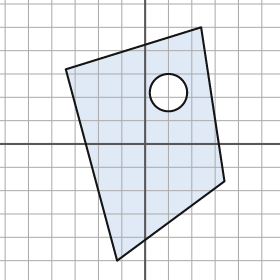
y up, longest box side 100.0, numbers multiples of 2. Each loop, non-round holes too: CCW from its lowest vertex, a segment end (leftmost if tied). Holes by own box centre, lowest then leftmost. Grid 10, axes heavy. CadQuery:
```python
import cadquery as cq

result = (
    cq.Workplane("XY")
    .moveTo(-12.0, -50.0)
    .lineTo(34.0, -16.0)
    .lineTo(24.0, 50.0)
    .lineTo(-34.0, 32.0)
    .close()
    .moveTo(10.0, 22.0)
    .circle(8.0)
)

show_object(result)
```